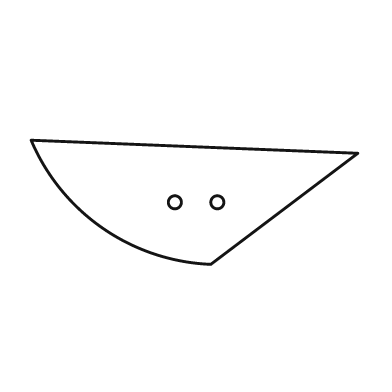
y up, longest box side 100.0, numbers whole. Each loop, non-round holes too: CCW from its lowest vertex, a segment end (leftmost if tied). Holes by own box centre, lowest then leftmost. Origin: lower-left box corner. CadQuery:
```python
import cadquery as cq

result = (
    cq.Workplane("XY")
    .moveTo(55.0, 0.0)
    .lineTo(100.0, 34.0)
    .lineTo(0.0, 38.0)
    .threePointArc((22.0, 11.0), (55.0, 0.0))
    .close()
    .moveTo(44.0, 19.0)
    .circle(2.0)
    .moveTo(57.0, 19.0)
    .circle(2.0)
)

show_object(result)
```